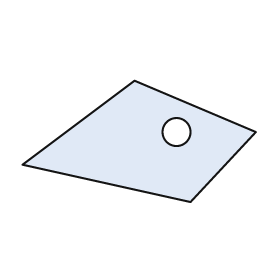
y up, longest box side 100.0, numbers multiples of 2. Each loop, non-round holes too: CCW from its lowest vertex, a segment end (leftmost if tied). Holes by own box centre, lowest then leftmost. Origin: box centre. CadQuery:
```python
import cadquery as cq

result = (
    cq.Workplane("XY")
    .moveTo(22.0, -26.0)
    .lineTo(50.0, 4.0)
    .lineTo(-2.0, 26.0)
    .lineTo(-50.0, -10.0)
    .close()
    .moveTo(16.0, 4.0)
    .circle(6.0)
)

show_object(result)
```